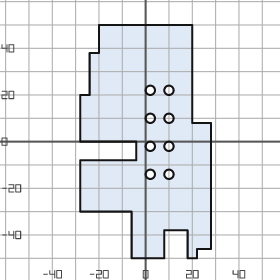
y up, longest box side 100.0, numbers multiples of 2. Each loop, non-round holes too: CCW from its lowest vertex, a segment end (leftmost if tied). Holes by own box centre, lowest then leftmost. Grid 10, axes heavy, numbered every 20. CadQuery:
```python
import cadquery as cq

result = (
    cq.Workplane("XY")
    .moveTo(-6.0, -50.0)
    .lineTo(8.0, -50.0)
    .lineTo(8.0, -38.0)
    .lineTo(18.0, -38.0)
    .lineTo(18.0, -50.0)
    .lineTo(22.0, -50.0)
    .lineTo(22.0, -46.0)
    .lineTo(28.0, -46.0)
    .lineTo(28.0, 8.0)
    .lineTo(20.0, 8.0)
    .lineTo(20.0, 50.0)
    .lineTo(-20.0, 50.0)
    .lineTo(-20.0, 38.0)
    .lineTo(-24.0, 38.0)
    .lineTo(-24.0, 20.0)
    .lineTo(-28.0, 20.0)
    .lineTo(-28.0, 0.0)
    .lineTo(-4.0, 0.0)
    .lineTo(-4.0, -8.0)
    .lineTo(-28.0, -8.0)
    .lineTo(-28.0, -30.0)
    .lineTo(-6.0, -30.0)
    .close()
    .moveTo(2.0, -14.0)
    .circle(2.0)
    .moveTo(10.0, -14.0)
    .circle(2.0)
    .moveTo(2.0, -2.0)
    .circle(2.0)
    .moveTo(10.0, -2.0)
    .circle(2.0)
    .moveTo(2.0, 10.0)
    .circle(2.0)
    .moveTo(10.0, 10.0)
    .circle(2.0)
    .moveTo(2.0, 22.0)
    .circle(2.0)
    .moveTo(10.0, 22.0)
    .circle(2.0)
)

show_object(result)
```